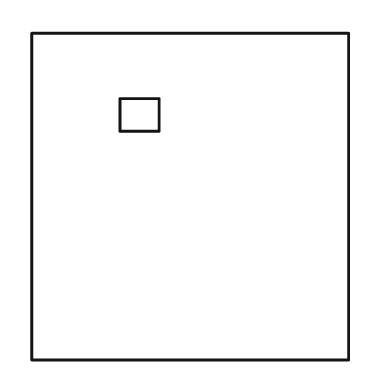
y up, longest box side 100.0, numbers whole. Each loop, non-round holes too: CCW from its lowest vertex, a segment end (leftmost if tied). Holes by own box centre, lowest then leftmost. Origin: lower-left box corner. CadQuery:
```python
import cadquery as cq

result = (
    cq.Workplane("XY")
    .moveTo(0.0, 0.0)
    .lineTo(97.0, 0.0)
    .lineTo(97.0, 100.0)
    .lineTo(0.0, 100.0)
    .close()
    .moveTo(27.0, 70.0)
    .lineTo(39.0, 70.0)
    .lineTo(39.0, 80.0)
    .lineTo(27.0, 80.0)
    .close()
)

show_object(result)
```